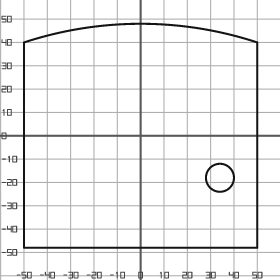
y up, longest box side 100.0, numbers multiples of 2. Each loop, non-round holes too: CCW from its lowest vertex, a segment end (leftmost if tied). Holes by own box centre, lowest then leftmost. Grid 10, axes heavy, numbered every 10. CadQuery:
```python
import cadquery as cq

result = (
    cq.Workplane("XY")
    .moveTo(-50.0, -48.0)
    .lineTo(50.0, -48.0)
    .lineTo(50.0, 40.0)
    .threePointArc((0.0, 48.0), (-50.0, 40.0))
    .close()
    .moveTo(34.0, -18.0)
    .circle(6.0)
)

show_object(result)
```